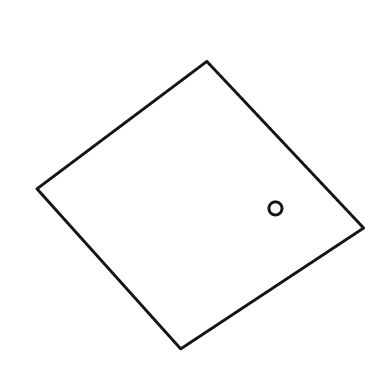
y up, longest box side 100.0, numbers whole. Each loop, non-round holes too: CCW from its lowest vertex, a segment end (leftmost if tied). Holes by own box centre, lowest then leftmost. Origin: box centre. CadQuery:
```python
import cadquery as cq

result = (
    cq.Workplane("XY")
    .moveTo(-6.0, -44.0)
    .lineTo(50.0, -7.0)
    .lineTo(2.0, 44.0)
    .lineTo(-50.0, 5.0)
    .close()
    .moveTo(23.0, -1.0)
    .circle(2.0)
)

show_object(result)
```